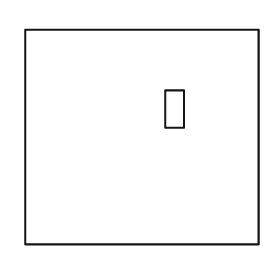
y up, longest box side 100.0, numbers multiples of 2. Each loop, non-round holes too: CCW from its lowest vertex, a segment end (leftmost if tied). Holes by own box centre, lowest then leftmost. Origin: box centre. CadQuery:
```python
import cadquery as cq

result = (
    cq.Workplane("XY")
    .moveTo(-50.0, -46.0)
    .lineTo(50.0, -46.0)
    .lineTo(50.0, 46.0)
    .lineTo(-50.0, 46.0)
    .close()
    .moveTo(10.0, 4.0)
    .lineTo(18.0, 4.0)
    .lineTo(18.0, 20.0)
    .lineTo(10.0, 20.0)
    .close()
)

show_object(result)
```